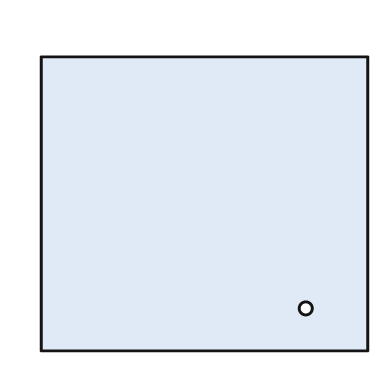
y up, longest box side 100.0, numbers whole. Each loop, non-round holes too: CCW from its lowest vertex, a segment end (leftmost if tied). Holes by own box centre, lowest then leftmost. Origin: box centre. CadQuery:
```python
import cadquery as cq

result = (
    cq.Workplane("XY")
    .moveTo(-50.0, -45.0)
    .lineTo(50.0, -45.0)
    .lineTo(50.0, 45.0)
    .lineTo(-50.0, 45.0)
    .close()
    .moveTo(31.0, -32.0)
    .circle(2.0)
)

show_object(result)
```